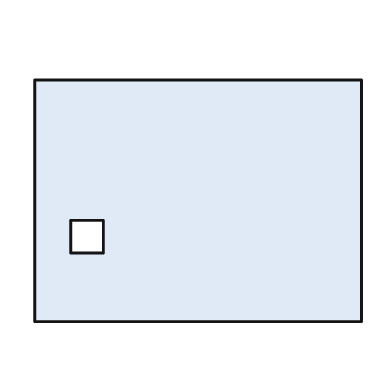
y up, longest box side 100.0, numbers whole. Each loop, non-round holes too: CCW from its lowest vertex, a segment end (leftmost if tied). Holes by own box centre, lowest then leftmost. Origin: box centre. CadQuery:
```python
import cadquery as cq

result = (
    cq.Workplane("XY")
    .moveTo(-50.0, -37.0)
    .lineTo(50.0, -37.0)
    .lineTo(50.0, 37.0)
    .lineTo(-50.0, 37.0)
    .close()
    .moveTo(-39.0, -16.0)
    .lineTo(-29.0, -16.0)
    .lineTo(-29.0, -6.0)
    .lineTo(-39.0, -6.0)
    .close()
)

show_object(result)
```